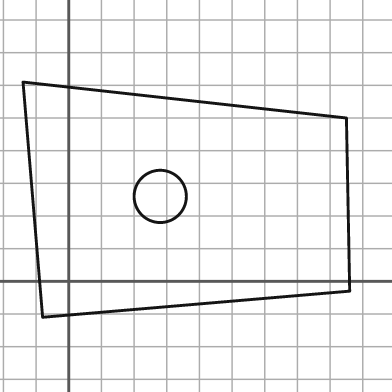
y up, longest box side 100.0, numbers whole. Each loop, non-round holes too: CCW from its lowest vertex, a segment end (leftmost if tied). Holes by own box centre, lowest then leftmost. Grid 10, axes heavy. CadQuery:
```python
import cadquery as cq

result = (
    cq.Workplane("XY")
    .moveTo(-8.0, -11.0)
    .lineTo(86.0, -3.0)
    .lineTo(85.0, 50.0)
    .lineTo(-14.0, 61.0)
    .close()
    .moveTo(28.0, 26.0)
    .circle(8.0)
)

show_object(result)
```